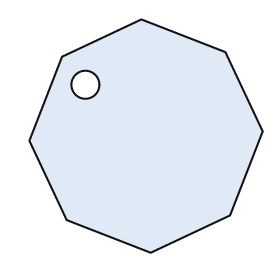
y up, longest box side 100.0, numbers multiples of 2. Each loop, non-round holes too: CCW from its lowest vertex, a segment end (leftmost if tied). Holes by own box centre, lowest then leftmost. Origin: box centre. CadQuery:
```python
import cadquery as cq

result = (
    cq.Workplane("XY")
    .moveTo(2.0, -50.0)
    .lineTo(36.0, -34.0)
    .lineTo(50.0, 2.0)
    .lineTo(34.0, 36.0)
    .lineTo(-2.0, 50.0)
    .lineTo(-36.0, 34.0)
    .lineTo(-50.0, -2.0)
    .lineTo(-34.0, -36.0)
    .close()
    .moveTo(-26.0, 22.0)
    .circle(6.0)
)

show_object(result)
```